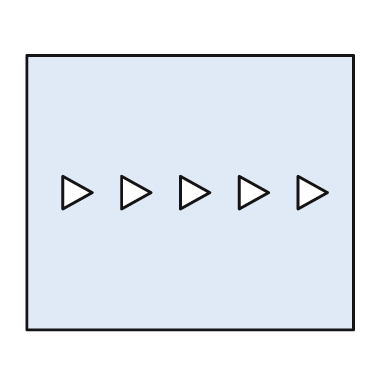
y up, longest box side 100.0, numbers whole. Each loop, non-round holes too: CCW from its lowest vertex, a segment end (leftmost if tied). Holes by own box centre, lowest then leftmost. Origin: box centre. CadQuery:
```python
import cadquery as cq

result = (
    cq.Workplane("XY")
    .moveTo(-50.0, -42.0)
    .lineTo(50.0, -42.0)
    .lineTo(50.0, 42.0)
    .lineTo(-50.0, 42.0)
    .close()
    .moveTo(-39.0, -5.0)
    .lineTo(-30.0, 0.0)
    .lineTo(-39.0, 5.0)
    .close()
    .moveTo(-21.0, -5.0)
    .lineTo(-12.0, 0.0)
    .lineTo(-21.0, 5.0)
    .close()
    .moveTo(-3.0, -5.0)
    .lineTo(6.0, 0.0)
    .lineTo(-3.0, 5.0)
    .close()
    .moveTo(15.0, -5.0)
    .lineTo(24.0, 0.0)
    .lineTo(15.0, 5.0)
    .close()
    .moveTo(33.0, -5.0)
    .lineTo(42.0, 0.0)
    .lineTo(33.0, 5.0)
    .close()
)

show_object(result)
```